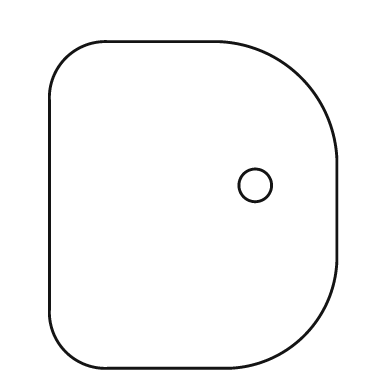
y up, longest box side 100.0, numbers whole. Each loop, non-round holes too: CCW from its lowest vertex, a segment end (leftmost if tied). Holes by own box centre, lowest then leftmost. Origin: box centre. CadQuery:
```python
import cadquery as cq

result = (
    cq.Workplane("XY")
    .moveTo(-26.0, -50.0)
    .lineTo(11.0, -50.0)
    .threePointArc((34.0, -40.0), (44.0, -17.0))
    .lineTo(44.0, 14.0)
    .threePointArc((33.0, 39.0), (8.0, 50.0))
    .lineTo(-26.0, 50.0)
    .threePointArc((-39.0, 45.0), (-44.0, 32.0))
    .lineTo(-44.0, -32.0)
    .threePointArc((-39.0, -45.0), (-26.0, -50.0))
    .close()
    .moveTo(19.0, 6.0)
    .circle(5.0)
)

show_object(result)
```